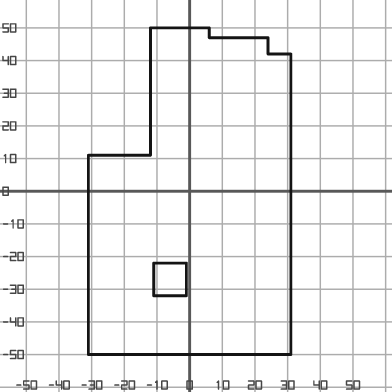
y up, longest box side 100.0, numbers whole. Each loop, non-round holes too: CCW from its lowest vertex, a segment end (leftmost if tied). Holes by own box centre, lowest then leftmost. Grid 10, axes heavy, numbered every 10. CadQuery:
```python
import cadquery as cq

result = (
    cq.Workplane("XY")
    .moveTo(-31.0, -50.0)
    .lineTo(31.0, -50.0)
    .lineTo(31.0, 42.0)
    .lineTo(24.0, 42.0)
    .lineTo(24.0, 47.0)
    .lineTo(6.0, 47.0)
    .lineTo(6.0, 50.0)
    .lineTo(-12.0, 50.0)
    .lineTo(-12.0, 11.0)
    .lineTo(-31.0, 11.0)
    .close()
    .moveTo(-11.0, -32.0)
    .lineTo(-1.0, -32.0)
    .lineTo(-1.0, -22.0)
    .lineTo(-11.0, -22.0)
    .close()
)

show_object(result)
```